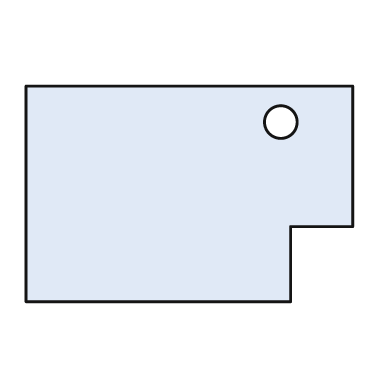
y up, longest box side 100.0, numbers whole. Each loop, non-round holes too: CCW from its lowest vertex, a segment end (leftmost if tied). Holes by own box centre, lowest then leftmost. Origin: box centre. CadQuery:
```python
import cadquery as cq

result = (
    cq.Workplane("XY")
    .moveTo(-50.0, -33.0)
    .lineTo(31.0, -33.0)
    .lineTo(31.0, -10.0)
    .lineTo(50.0, -10.0)
    .lineTo(50.0, 33.0)
    .lineTo(-50.0, 33.0)
    .close()
    .moveTo(28.0, 22.0)
    .circle(5.0)
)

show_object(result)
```